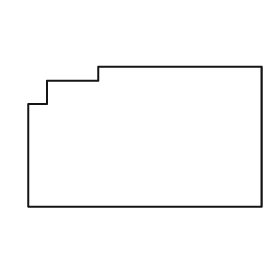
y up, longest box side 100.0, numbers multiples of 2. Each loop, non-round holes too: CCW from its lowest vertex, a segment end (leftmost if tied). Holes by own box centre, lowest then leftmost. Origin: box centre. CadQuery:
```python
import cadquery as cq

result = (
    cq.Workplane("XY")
    .moveTo(-50.0, -30.0)
    .lineTo(50.0, -30.0)
    .lineTo(50.0, 30.0)
    .lineTo(-20.0, 30.0)
    .lineTo(-20.0, 24.0)
    .lineTo(-42.0, 24.0)
    .lineTo(-42.0, 14.0)
    .lineTo(-50.0, 14.0)
    .close()
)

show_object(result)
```